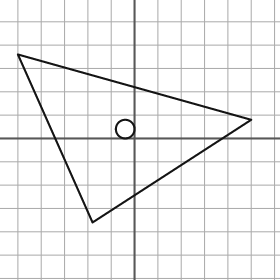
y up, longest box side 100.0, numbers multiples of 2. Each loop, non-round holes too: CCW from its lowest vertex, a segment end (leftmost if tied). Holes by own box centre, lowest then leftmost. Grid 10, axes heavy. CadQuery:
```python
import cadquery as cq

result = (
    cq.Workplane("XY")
    .moveTo(-18.0, -36.0)
    .lineTo(50.0, 8.0)
    .lineTo(-50.0, 36.0)
    .close()
    .moveTo(-4.0, 4.0)
    .circle(4.0)
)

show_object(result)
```